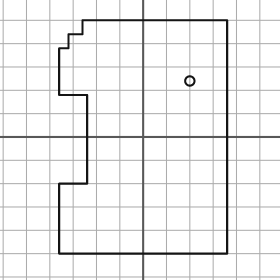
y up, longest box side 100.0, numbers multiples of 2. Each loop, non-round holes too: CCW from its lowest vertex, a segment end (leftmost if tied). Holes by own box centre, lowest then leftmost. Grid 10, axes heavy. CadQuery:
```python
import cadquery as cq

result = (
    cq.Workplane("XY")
    .moveTo(-36.0, -50.0)
    .lineTo(36.0, -50.0)
    .lineTo(36.0, 50.0)
    .lineTo(-26.0, 50.0)
    .lineTo(-26.0, 44.0)
    .lineTo(-32.0, 44.0)
    .lineTo(-32.0, 38.0)
    .lineTo(-36.0, 38.0)
    .lineTo(-36.0, 18.0)
    .lineTo(-24.0, 18.0)
    .lineTo(-24.0, -20.0)
    .lineTo(-36.0, -20.0)
    .close()
    .moveTo(20.0, 24.0)
    .circle(2.0)
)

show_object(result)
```